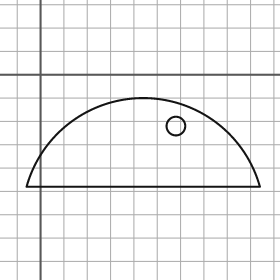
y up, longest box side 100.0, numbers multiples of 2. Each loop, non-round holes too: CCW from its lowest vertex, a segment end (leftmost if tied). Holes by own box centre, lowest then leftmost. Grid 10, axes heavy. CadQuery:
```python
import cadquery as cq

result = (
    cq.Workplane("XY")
    .moveTo(-6.0, -48.0)
    .lineTo(94.0, -48.0)
    .threePointArc((44.0, -10.0), (-6.0, -48.0))
    .close()
    .moveTo(58.0, -22.0)
    .circle(4.0)
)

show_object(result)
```